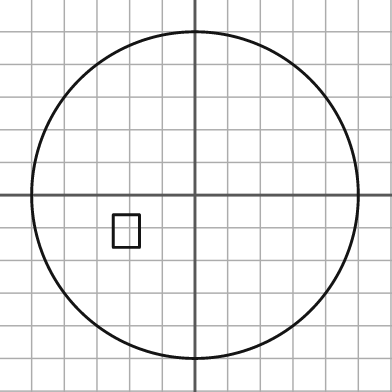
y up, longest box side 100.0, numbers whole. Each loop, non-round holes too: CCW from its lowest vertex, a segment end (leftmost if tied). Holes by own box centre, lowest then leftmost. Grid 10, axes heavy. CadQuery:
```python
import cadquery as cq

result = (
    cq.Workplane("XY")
    .moveTo(0.0, 0.0)
    .circle(50.0)
    .moveTo(-25.0, -16.0)
    .lineTo(-17.0, -16.0)
    .lineTo(-17.0, -6.0)
    .lineTo(-25.0, -6.0)
    .close()
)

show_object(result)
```